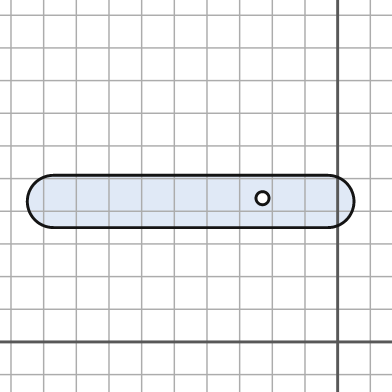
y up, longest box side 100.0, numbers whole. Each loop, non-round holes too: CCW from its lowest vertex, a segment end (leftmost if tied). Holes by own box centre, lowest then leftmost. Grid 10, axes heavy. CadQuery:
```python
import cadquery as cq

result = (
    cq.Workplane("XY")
    .moveTo(-87.0, 35.0)
    .lineTo(-3.0, 35.0)
    .threePointArc((5.0, 43.0), (-3.0, 51.0))
    .lineTo(-87.0, 51.0)
    .threePointArc((-95.0, 43.0), (-87.0, 35.0))
    .close()
    .moveTo(-23.0, 44.0)
    .circle(2.0)
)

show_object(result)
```